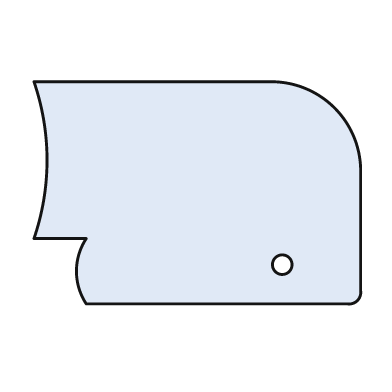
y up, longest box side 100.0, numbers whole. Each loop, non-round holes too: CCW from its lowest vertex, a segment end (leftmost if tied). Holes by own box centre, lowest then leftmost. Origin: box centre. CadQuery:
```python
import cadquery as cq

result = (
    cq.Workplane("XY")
    .moveTo(-34.0, -34.0)
    .lineTo(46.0, -34.0)
    .threePointArc((49.0, -33.0), (50.0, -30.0))
    .lineTo(50.0, 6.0)
    .threePointArc((42.0, 26.0), (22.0, 34.0))
    .lineTo(-50.0, 34.0)
    .threePointArc((-46.0, 10.0), (-50.0, -14.0))
    .lineTo(-34.0, -14.0)
    .threePointArc((-37.0, -24.0), (-34.0, -34.0))
    .close()
    .moveTo(26.0, -22.0)
    .circle(3.0)
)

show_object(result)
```